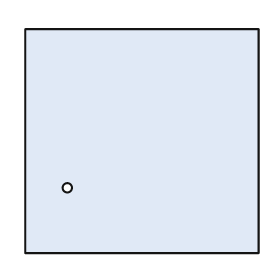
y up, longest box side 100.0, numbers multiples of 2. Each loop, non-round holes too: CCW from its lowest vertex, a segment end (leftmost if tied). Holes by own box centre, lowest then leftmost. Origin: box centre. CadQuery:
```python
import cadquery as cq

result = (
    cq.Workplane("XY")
    .moveTo(-50.0, -48.0)
    .lineTo(50.0, -48.0)
    .lineTo(50.0, 48.0)
    .lineTo(-50.0, 48.0)
    .close()
    .moveTo(-32.0, -20.0)
    .circle(2.0)
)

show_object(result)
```